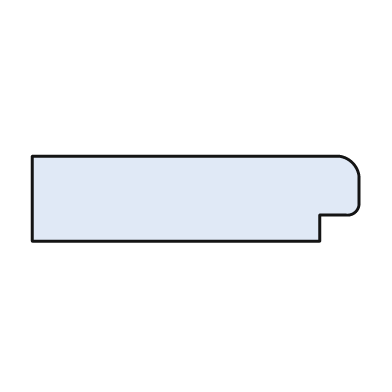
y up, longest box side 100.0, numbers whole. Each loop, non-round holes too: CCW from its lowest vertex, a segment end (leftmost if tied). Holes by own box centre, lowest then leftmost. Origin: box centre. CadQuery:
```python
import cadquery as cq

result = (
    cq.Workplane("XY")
    .moveTo(-50.0, -13.0)
    .lineTo(38.0, -13.0)
    .lineTo(38.0, -5.0)
    .lineTo(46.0, -5.0)
    .threePointArc((49.0, -4.0), (50.0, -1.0))
    .lineTo(50.0, 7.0)
    .threePointArc((48.0, 11.0), (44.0, 13.0))
    .lineTo(-50.0, 13.0)
    .close()
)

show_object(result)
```